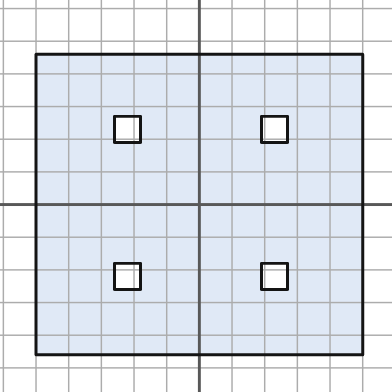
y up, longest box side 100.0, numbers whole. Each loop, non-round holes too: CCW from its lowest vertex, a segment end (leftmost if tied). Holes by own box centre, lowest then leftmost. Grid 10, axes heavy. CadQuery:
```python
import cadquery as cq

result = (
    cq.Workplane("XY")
    .moveTo(-50.0, -46.0)
    .lineTo(50.0, -46.0)
    .lineTo(50.0, 46.0)
    .lineTo(-50.0, 46.0)
    .close()
    .moveTo(-26.0, -26.0)
    .lineTo(-18.0, -26.0)
    .lineTo(-18.0, -18.0)
    .lineTo(-26.0, -18.0)
    .close()
    .moveTo(19.0, -26.0)
    .lineTo(27.0, -26.0)
    .lineTo(27.0, -18.0)
    .lineTo(19.0, -18.0)
    .close()
    .moveTo(-26.0, 19.0)
    .lineTo(-18.0, 19.0)
    .lineTo(-18.0, 27.0)
    .lineTo(-26.0, 27.0)
    .close()
    .moveTo(19.0, 19.0)
    .lineTo(27.0, 19.0)
    .lineTo(27.0, 27.0)
    .lineTo(19.0, 27.0)
    .close()
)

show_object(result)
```